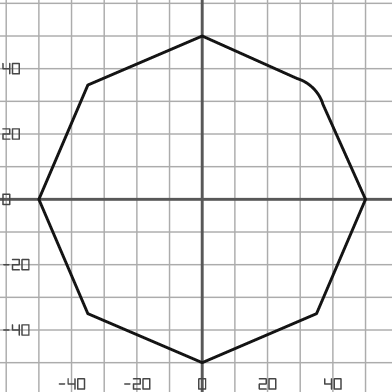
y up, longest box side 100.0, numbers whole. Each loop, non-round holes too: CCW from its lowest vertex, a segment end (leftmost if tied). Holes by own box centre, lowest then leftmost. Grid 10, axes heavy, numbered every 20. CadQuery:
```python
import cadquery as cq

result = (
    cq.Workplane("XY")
    .moveTo(0.0, -50.0)
    .lineTo(35.0, -35.0)
    .lineTo(50.0, 0.0)
    .lineTo(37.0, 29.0)
    .threePointArc((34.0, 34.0), (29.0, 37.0))
    .lineTo(0.0, 50.0)
    .lineTo(-35.0, 35.0)
    .lineTo(-50.0, 0.0)
    .lineTo(-35.0, -35.0)
    .close()
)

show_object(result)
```